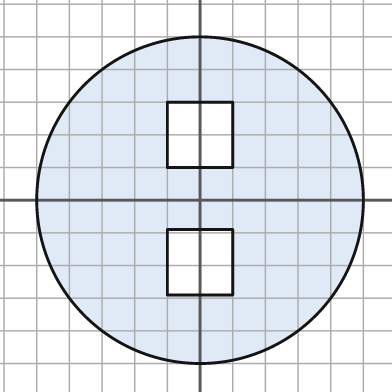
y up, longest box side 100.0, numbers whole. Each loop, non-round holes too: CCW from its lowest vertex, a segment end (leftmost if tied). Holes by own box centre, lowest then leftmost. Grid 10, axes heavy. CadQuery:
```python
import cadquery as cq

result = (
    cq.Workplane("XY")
    .moveTo(0.0, 0.0)
    .circle(50.0)
    .moveTo(-10.0, -29.0)
    .lineTo(10.0, -29.0)
    .lineTo(10.0, -9.0)
    .lineTo(-10.0, -9.0)
    .close()
    .moveTo(-10.0, 10.0)
    .lineTo(10.0, 10.0)
    .lineTo(10.0, 30.0)
    .lineTo(-10.0, 30.0)
    .close()
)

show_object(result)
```